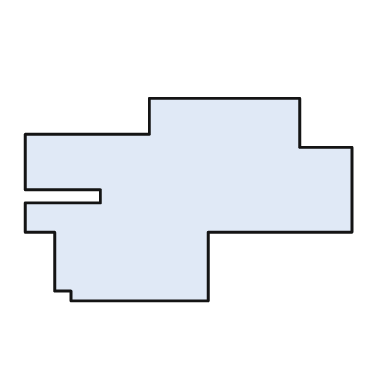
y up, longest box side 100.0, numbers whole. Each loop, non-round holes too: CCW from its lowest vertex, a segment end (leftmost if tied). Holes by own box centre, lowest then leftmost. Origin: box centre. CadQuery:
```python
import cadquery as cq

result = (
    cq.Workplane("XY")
    .moveTo(-36.0, -31.0)
    .lineTo(6.0, -31.0)
    .lineTo(6.0, -10.0)
    .lineTo(50.0, -10.0)
    .lineTo(50.0, 16.0)
    .lineTo(34.0, 16.0)
    .lineTo(34.0, 31.0)
    .lineTo(-12.0, 31.0)
    .lineTo(-12.0, 20.0)
    .lineTo(-50.0, 20.0)
    .lineTo(-50.0, 3.0)
    .lineTo(-27.0, 3.0)
    .lineTo(-27.0, -1.0)
    .lineTo(-50.0, -1.0)
    .lineTo(-50.0, -10.0)
    .lineTo(-41.0, -10.0)
    .lineTo(-41.0, -28.0)
    .lineTo(-36.0, -28.0)
    .close()
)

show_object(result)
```